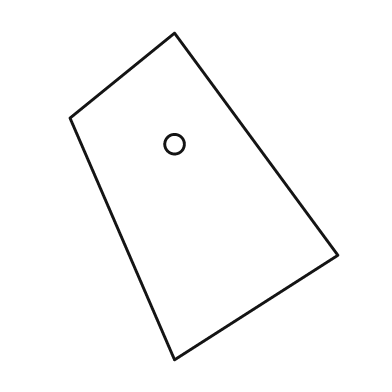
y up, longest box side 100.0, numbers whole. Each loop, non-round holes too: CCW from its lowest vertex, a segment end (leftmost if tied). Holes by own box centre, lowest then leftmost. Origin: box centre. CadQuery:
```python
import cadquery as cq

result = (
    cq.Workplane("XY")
    .moveTo(-9.0, -50.0)
    .lineTo(41.0, -18.0)
    .lineTo(-9.0, 50.0)
    .lineTo(-41.0, 24.0)
    .close()
    .moveTo(-9.0, 16.0)
    .circle(3.0)
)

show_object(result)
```